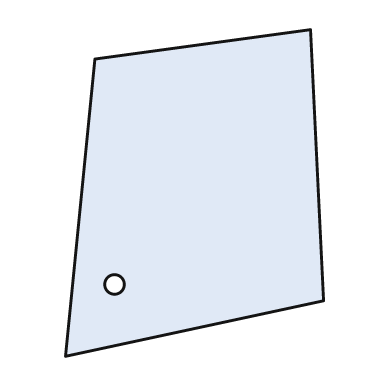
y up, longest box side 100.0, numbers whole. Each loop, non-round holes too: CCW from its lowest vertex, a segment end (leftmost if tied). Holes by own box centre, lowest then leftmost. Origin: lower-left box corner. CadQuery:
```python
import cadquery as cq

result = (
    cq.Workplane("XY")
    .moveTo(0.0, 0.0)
    .lineTo(79.0, 17.0)
    .lineTo(75.0, 100.0)
    .lineTo(9.0, 91.0)
    .close()
    .moveTo(15.0, 22.0)
    .circle(3.0)
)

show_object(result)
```